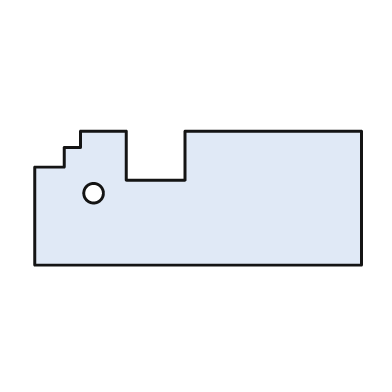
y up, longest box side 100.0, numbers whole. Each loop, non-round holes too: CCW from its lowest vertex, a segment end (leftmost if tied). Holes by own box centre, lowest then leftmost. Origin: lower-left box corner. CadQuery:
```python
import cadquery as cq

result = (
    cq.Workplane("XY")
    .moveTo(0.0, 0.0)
    .lineTo(100.0, 0.0)
    .lineTo(100.0, 41.0)
    .lineTo(46.0, 41.0)
    .lineTo(46.0, 26.0)
    .lineTo(28.0, 26.0)
    .lineTo(28.0, 41.0)
    .lineTo(14.0, 41.0)
    .lineTo(14.0, 36.0)
    .lineTo(9.0, 36.0)
    .lineTo(9.0, 30.0)
    .lineTo(0.0, 30.0)
    .close()
    .moveTo(18.0, 22.0)
    .circle(3.0)
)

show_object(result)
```